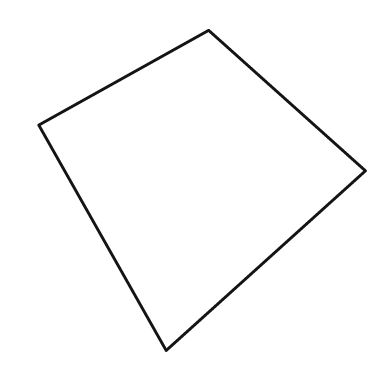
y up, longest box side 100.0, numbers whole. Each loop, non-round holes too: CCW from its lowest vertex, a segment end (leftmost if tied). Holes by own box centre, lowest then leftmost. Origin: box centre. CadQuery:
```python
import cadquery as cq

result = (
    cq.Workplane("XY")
    .moveTo(-11.0, -49.0)
    .lineTo(50.0, 6.0)
    .lineTo(2.0, 49.0)
    .lineTo(-50.0, 20.0)
    .close()
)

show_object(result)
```